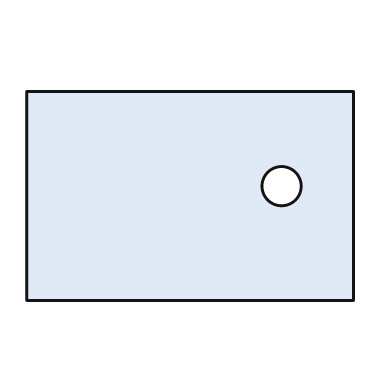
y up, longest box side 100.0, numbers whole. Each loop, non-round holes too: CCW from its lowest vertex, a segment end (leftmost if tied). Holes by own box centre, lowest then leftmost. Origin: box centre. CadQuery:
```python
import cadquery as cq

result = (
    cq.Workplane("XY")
    .moveTo(-50.0, -32.0)
    .lineTo(50.0, -32.0)
    .lineTo(50.0, 32.0)
    .lineTo(-50.0, 32.0)
    .close()
    .moveTo(28.0, 3.0)
    .circle(6.0)
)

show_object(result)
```